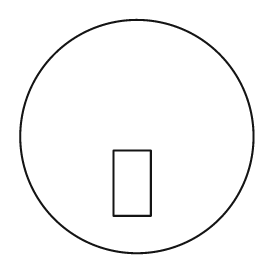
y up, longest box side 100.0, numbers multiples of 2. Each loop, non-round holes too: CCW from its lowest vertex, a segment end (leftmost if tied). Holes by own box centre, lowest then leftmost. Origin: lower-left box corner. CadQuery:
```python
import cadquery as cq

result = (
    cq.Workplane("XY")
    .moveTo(50.0, 50.0)
    .circle(50.0)
    .moveTo(40.0, 16.0)
    .lineTo(56.0, 16.0)
    .lineTo(56.0, 44.0)
    .lineTo(40.0, 44.0)
    .close()
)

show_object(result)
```